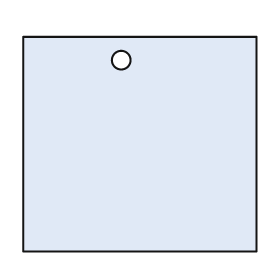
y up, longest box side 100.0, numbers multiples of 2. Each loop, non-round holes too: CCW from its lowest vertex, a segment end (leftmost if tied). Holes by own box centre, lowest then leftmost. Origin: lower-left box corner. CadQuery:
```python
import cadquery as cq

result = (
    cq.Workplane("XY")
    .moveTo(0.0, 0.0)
    .lineTo(100.0, 0.0)
    .lineTo(100.0, 92.0)
    .lineTo(0.0, 92.0)
    .close()
    .moveTo(42.0, 82.0)
    .circle(4.0)
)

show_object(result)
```